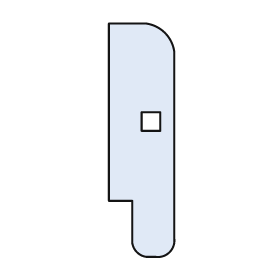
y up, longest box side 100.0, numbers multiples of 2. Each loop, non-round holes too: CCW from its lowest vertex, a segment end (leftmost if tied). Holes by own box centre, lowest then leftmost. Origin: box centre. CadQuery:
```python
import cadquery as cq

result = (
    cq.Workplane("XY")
    .moveTo(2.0, -50.0)
    .lineTo(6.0, -50.0)
    .threePointArc((12.0, -48.0), (14.0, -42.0))
    .lineTo(14.0, 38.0)
    .threePointArc((10.0, 46.0), (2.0, 50.0))
    .lineTo(-14.0, 50.0)
    .lineTo(-14.0, -26.0)
    .lineTo(-4.0, -26.0)
    .lineTo(-4.0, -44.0)
    .threePointArc((-2.0, -48.0), (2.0, -50.0))
    .close()
    .moveTo(0.0, 4.0)
    .lineTo(8.0, 4.0)
    .lineTo(8.0, 12.0)
    .lineTo(0.0, 12.0)
    .close()
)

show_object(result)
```